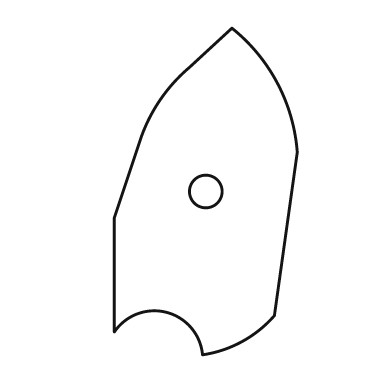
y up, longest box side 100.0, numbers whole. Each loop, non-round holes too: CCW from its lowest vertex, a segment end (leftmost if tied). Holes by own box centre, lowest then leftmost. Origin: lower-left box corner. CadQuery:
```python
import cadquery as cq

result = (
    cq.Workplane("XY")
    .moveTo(27.0, 0.0)
    .threePointArc((39.0, 4.0), (49.0, 12.0))
    .lineTo(56.0, 62.0)
    .threePointArc((50.0, 83.0), (36.0, 100.0))
    .lineTo(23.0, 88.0)
    .threePointArc((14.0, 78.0), (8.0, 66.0))
    .lineTo(0.0, 42.0)
    .lineTo(0.0, 7.0)
    .threePointArc((16.0, 13.0), (27.0, 0.0))
    .close()
    .moveTo(28.0, 50.0)
    .circle(5.0)
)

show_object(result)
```